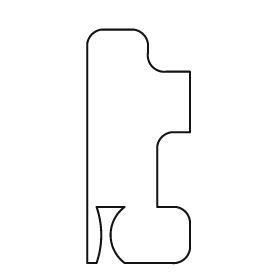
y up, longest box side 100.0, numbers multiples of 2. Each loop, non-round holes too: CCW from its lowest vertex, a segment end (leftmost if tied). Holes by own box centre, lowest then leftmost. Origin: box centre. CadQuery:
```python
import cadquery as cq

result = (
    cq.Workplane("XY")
    .moveTo(-22.0, -50.0)
    .lineTo(-18.0, -50.0)
    .threePointArc((-16.0, -38.0), (-18.0, -26.0))
    .lineTo(-6.0, -26.0)
    .threePointArc((-12.0, -38.0), (-6.0, -50.0))
    .lineTo(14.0, -50.0)
    .threePointArc((20.0, -48.0), (22.0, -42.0))
    .lineTo(22.0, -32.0)
    .threePointArc((20.0, -28.0), (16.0, -26.0))
    .lineTo(8.0, -26.0)
    .lineTo(8.0, 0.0)
    .threePointArc((10.0, 4.0), (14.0, 6.0))
    .lineTo(22.0, 6.0)
    .lineTo(22.0, 32.0)
    .lineTo(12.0, 32.0)
    .threePointArc((6.0, 34.0), (4.0, 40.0))
    .lineTo(4.0, 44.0)
    .threePointArc((2.0, 48.0), (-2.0, 50.0))
    .lineTo(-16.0, 50.0)
    .threePointArc((-20.0, 48.0), (-22.0, 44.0))
    .close()
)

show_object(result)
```